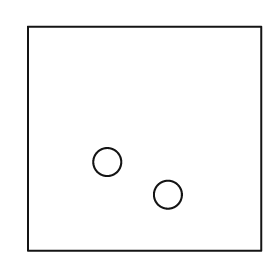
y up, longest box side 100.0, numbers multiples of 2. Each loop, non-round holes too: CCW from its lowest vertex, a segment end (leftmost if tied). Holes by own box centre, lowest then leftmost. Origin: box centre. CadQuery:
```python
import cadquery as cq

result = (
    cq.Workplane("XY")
    .moveTo(-50.0, -48.0)
    .lineTo(50.0, -48.0)
    .lineTo(50.0, 48.0)
    .lineTo(-50.0, 48.0)
    .close()
    .moveTo(10.0, -24.0)
    .circle(6.0)
    .moveTo(-16.0, -10.0)
    .circle(6.0)
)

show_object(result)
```